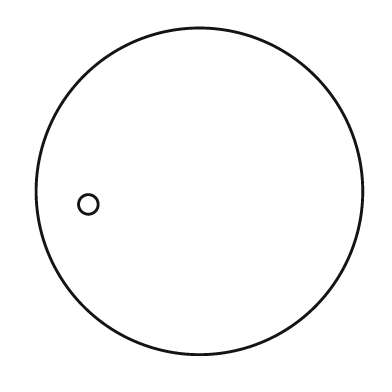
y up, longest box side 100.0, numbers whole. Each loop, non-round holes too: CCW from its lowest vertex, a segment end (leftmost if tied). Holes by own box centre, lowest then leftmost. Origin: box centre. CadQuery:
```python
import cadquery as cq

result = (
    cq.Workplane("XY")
    .moveTo(0.0, 0.0)
    .circle(50.0)
    .moveTo(-34.0, -4.0)
    .circle(3.0)
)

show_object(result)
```